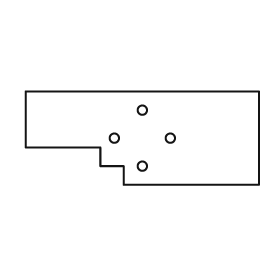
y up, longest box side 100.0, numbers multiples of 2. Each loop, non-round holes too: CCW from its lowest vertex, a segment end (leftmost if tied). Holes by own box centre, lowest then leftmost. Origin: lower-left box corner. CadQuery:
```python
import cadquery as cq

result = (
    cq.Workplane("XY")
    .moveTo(42.0, 0.0)
    .lineTo(100.0, 0.0)
    .lineTo(100.0, 40.0)
    .lineTo(0.0, 40.0)
    .lineTo(0.0, 16.0)
    .lineTo(32.0, 16.0)
    .lineTo(32.0, 8.0)
    .lineTo(42.0, 8.0)
    .close()
    .moveTo(50.0, 8.0)
    .circle(2.0)
    .moveTo(38.0, 20.0)
    .circle(2.0)
    .moveTo(62.0, 20.0)
    .circle(2.0)
    .moveTo(50.0, 32.0)
    .circle(2.0)
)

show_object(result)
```